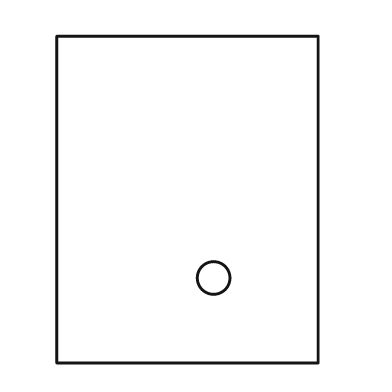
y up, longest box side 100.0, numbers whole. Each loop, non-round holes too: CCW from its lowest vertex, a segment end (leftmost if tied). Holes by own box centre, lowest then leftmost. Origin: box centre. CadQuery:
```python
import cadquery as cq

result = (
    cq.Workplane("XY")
    .moveTo(-40.0, -50.0)
    .lineTo(40.0, -50.0)
    .lineTo(40.0, 50.0)
    .lineTo(-40.0, 50.0)
    .close()
    .moveTo(8.0, -24.0)
    .circle(5.0)
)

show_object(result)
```